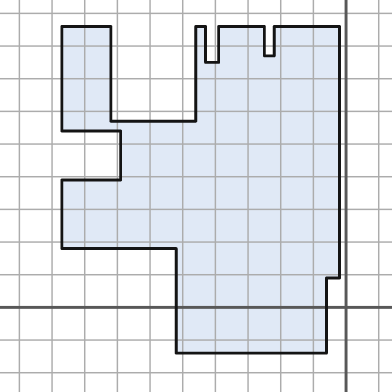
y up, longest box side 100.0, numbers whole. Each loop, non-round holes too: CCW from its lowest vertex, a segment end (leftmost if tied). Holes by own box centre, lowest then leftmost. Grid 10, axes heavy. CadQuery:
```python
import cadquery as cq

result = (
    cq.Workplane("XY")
    .moveTo(-52.0, -14.0)
    .lineTo(-6.0, -14.0)
    .lineTo(-6.0, 9.0)
    .lineTo(-2.0, 9.0)
    .lineTo(-2.0, 86.0)
    .lineTo(-22.0, 86.0)
    .lineTo(-22.0, 77.0)
    .lineTo(-25.0, 77.0)
    .lineTo(-25.0, 86.0)
    .lineTo(-39.0, 86.0)
    .lineTo(-39.0, 75.0)
    .lineTo(-43.0, 75.0)
    .lineTo(-43.0, 86.0)
    .lineTo(-46.0, 86.0)
    .lineTo(-46.0, 57.0)
    .lineTo(-72.0, 57.0)
    .lineTo(-72.0, 86.0)
    .lineTo(-87.0, 86.0)
    .lineTo(-87.0, 54.0)
    .lineTo(-69.0, 54.0)
    .lineTo(-69.0, 39.0)
    .lineTo(-87.0, 39.0)
    .lineTo(-87.0, 18.0)
    .lineTo(-52.0, 18.0)
    .close()
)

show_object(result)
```